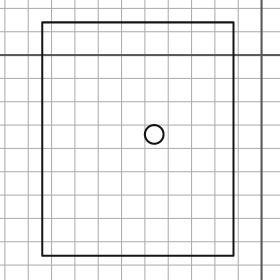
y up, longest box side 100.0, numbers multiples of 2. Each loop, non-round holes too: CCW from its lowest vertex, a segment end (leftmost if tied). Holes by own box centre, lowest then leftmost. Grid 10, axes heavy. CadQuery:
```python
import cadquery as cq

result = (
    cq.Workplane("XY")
    .moveTo(-94.0, -86.0)
    .lineTo(-12.0, -86.0)
    .lineTo(-12.0, 14.0)
    .lineTo(-94.0, 14.0)
    .close()
    .moveTo(-46.0, -34.0)
    .circle(4.0)
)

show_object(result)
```